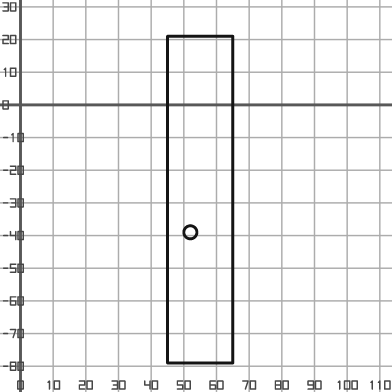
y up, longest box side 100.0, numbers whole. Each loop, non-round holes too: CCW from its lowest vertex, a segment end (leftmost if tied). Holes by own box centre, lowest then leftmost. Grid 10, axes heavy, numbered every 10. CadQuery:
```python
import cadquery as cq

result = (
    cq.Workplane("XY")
    .moveTo(45.0, -79.0)
    .lineTo(65.0, -79.0)
    .lineTo(65.0, 21.0)
    .lineTo(45.0, 21.0)
    .close()
    .moveTo(52.0, -39.0)
    .circle(2.0)
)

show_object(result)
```